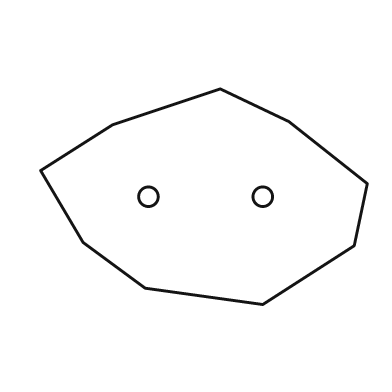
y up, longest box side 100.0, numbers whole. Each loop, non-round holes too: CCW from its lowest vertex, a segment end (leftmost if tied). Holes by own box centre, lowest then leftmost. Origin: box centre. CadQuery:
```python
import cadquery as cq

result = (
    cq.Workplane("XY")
    .moveTo(18.0, -33.0)
    .lineTo(46.0, -15.0)
    .lineTo(50.0, 4.0)
    .lineTo(26.0, 23.0)
    .lineTo(5.0, 33.0)
    .lineTo(-28.0, 22.0)
    .lineTo(-50.0, 8.0)
    .lineTo(-37.0, -14.0)
    .lineTo(-18.0, -28.0)
    .close()
    .moveTo(-17.0, 0.0)
    .circle(3.0)
    .moveTo(18.0, 0.0)
    .circle(3.0)
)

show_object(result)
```